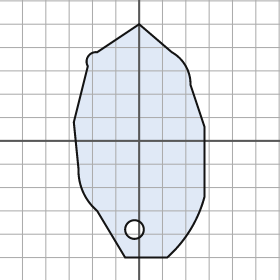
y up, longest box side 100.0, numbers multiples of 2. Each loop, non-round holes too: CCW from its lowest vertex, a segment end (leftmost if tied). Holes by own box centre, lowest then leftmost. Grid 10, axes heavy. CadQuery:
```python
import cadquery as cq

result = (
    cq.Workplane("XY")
    .moveTo(-6.0, -50.0)
    .lineTo(12.0, -50.0)
    .threePointArc((22.0, -38.0), (28.0, -24.0))
    .lineTo(28.0, 6.0)
    .lineTo(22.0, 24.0)
    .threePointArc((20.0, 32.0), (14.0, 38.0))
    .lineTo(0.0, 50.0)
    .lineTo(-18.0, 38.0)
    .threePointArc((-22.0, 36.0), (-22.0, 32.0))
    .lineTo(-28.0, 8.0)
    .lineTo(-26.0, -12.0)
    .threePointArc((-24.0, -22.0), (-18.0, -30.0))
    .close()
    .moveTo(-2.0, -38.0)
    .circle(4.0)
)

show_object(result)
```